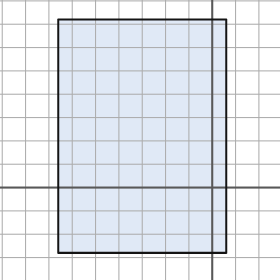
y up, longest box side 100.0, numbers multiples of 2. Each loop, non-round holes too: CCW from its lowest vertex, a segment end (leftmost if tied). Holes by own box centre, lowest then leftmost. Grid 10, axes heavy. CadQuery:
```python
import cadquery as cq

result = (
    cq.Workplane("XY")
    .moveTo(-66.0, -28.0)
    .lineTo(6.0, -28.0)
    .lineTo(6.0, 72.0)
    .lineTo(-66.0, 72.0)
    .close()
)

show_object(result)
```